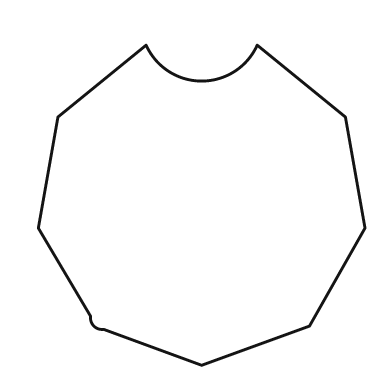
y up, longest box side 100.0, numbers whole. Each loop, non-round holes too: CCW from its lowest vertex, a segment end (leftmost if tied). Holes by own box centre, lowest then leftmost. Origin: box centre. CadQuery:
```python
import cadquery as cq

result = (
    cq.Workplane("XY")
    .moveTo(0.0, -49.0)
    .lineTo(33.0, -37.0)
    .lineTo(50.0, -7.0)
    .lineTo(44.0, 27.0)
    .lineTo(17.0, 49.0)
    .threePointArc((0.0, 38.0), (-17.0, 49.0))
    .lineTo(-44.0, 27.0)
    .lineTo(-50.0, -7.0)
    .lineTo(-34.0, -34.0)
    .threePointArc((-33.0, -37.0), (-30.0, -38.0))
    .close()
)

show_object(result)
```